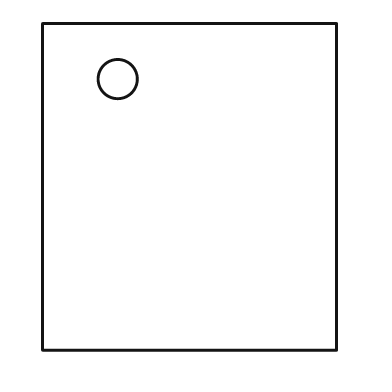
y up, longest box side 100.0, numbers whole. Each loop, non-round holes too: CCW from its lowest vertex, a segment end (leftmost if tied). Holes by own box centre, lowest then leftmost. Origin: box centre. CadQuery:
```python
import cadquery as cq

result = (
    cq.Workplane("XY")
    .moveTo(-45.0, -50.0)
    .lineTo(45.0, -50.0)
    .lineTo(45.0, 50.0)
    .lineTo(-45.0, 50.0)
    .close()
    .moveTo(-22.0, 33.0)
    .circle(6.0)
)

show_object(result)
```